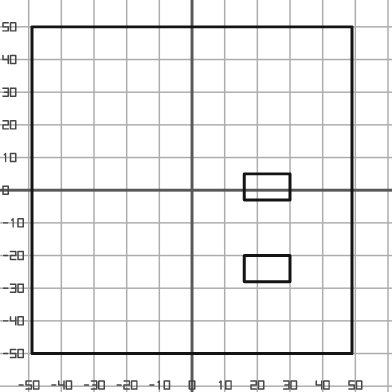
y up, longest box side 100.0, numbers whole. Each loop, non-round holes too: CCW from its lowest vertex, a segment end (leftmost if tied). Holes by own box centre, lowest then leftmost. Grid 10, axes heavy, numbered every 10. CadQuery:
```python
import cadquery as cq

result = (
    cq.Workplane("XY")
    .moveTo(-49.0, -50.0)
    .lineTo(49.0, -50.0)
    .lineTo(49.0, 50.0)
    .lineTo(-49.0, 50.0)
    .close()
    .moveTo(16.0, -28.0)
    .lineTo(30.0, -28.0)
    .lineTo(30.0, -20.0)
    .lineTo(16.0, -20.0)
    .close()
    .moveTo(16.0, -3.0)
    .lineTo(30.0, -3.0)
    .lineTo(30.0, 5.0)
    .lineTo(16.0, 5.0)
    .close()
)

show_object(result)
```